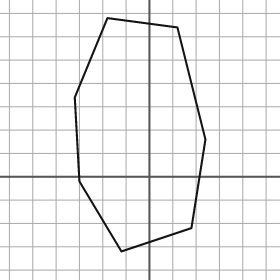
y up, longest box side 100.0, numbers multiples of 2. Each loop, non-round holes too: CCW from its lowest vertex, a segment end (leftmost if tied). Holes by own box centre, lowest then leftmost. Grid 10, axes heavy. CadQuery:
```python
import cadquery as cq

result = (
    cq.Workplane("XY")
    .moveTo(-12.0, -32.0)
    .lineTo(18.0, -22.0)
    .lineTo(24.0, 16.0)
    .lineTo(12.0, 64.0)
    .lineTo(-18.0, 68.0)
    .lineTo(-32.0, 34.0)
    .lineTo(-30.0, -2.0)
    .close()
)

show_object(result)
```